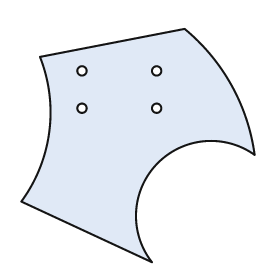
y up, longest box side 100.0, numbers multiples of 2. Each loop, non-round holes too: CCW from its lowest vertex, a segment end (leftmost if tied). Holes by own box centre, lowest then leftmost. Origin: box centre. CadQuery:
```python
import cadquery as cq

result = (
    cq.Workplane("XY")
    .moveTo(6.0, -50.0)
    .threePointArc((8.0, -8.0), (50.0, -4.0))
    .threePointArc((40.0, 26.0), (20.0, 50.0))
    .lineTo(-42.0, 38.0)
    .threePointArc((-38.0, 6.0), (-50.0, -24.0))
    .close()
    .moveTo(-24.0, 16.0)
    .circle(2.0)
    .moveTo(8.0, 16.0)
    .circle(2.0)
    .moveTo(-24.0, 32.0)
    .circle(2.0)
    .moveTo(8.0, 32.0)
    .circle(2.0)
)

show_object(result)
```